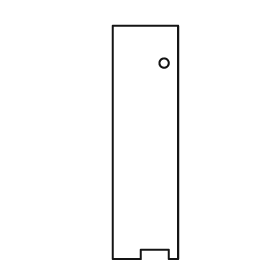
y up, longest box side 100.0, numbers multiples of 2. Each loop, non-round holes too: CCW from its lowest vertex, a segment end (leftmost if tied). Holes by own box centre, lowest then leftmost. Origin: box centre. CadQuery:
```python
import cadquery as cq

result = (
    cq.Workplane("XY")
    .moveTo(-14.0, -50.0)
    .lineTo(-2.0, -50.0)
    .lineTo(-2.0, -46.0)
    .lineTo(10.0, -46.0)
    .lineTo(10.0, -50.0)
    .lineTo(14.0, -50.0)
    .lineTo(14.0, 50.0)
    .lineTo(-14.0, 50.0)
    .close()
    .moveTo(8.0, 34.0)
    .circle(2.0)
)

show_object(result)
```